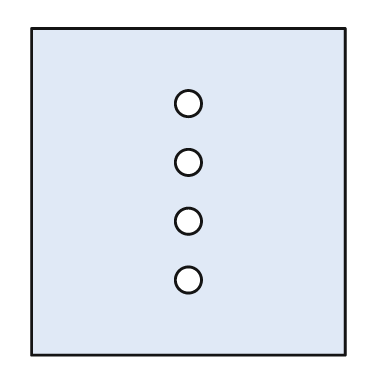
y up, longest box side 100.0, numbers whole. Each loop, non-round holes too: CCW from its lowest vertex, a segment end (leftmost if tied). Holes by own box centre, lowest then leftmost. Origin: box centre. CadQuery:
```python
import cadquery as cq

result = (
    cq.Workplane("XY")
    .moveTo(-48.0, -50.0)
    .lineTo(48.0, -50.0)
    .lineTo(48.0, 50.0)
    .lineTo(-48.0, 50.0)
    .close()
    .moveTo(0.0, -27.0)
    .circle(4.0)
    .moveTo(0.0, -9.0)
    .circle(4.0)
    .moveTo(0.0, 9.0)
    .circle(4.0)
    .moveTo(0.0, 27.0)
    .circle(4.0)
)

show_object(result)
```